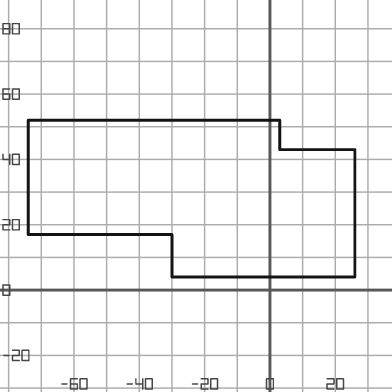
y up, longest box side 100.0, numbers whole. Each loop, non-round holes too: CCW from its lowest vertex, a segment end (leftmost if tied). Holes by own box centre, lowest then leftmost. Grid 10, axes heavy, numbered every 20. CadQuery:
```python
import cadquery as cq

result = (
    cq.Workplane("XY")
    .moveTo(-30.0, 4.0)
    .lineTo(26.0, 4.0)
    .lineTo(26.0, 43.0)
    .lineTo(3.0, 43.0)
    .lineTo(3.0, 52.0)
    .lineTo(-74.0, 52.0)
    .lineTo(-74.0, 17.0)
    .lineTo(-30.0, 17.0)
    .close()
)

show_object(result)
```